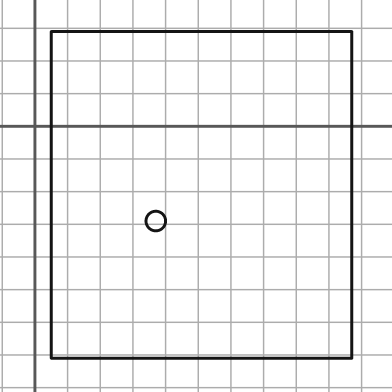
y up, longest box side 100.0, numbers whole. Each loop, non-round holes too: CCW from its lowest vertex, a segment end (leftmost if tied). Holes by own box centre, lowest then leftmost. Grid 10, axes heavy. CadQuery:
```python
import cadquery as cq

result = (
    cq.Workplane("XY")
    .moveTo(5.0, -71.0)
    .lineTo(97.0, -71.0)
    .lineTo(97.0, 29.0)
    .lineTo(5.0, 29.0)
    .close()
    .moveTo(37.0, -29.0)
    .circle(3.0)
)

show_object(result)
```